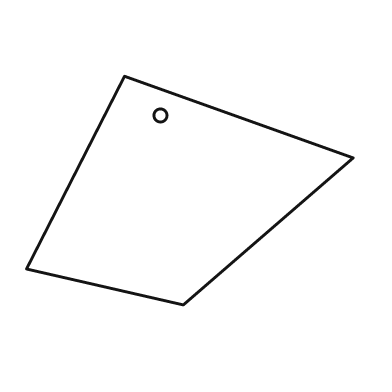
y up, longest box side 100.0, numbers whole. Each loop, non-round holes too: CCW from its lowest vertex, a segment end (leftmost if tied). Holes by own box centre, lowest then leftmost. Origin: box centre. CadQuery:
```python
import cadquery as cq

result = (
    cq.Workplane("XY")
    .moveTo(-2.0, -35.0)
    .lineTo(50.0, 10.0)
    .lineTo(-20.0, 35.0)
    .lineTo(-50.0, -24.0)
    .close()
    .moveTo(-9.0, 23.0)
    .circle(2.0)
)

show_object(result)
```